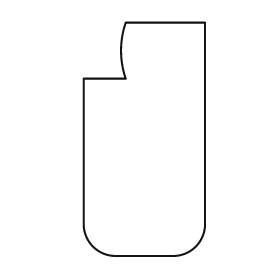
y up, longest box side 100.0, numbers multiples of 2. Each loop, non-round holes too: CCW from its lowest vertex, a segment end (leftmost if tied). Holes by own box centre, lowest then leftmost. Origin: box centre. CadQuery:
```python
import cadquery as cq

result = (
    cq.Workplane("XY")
    .moveTo(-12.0, -50.0)
    .lineTo(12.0, -50.0)
    .threePointArc((22.0, -46.0), (26.0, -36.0))
    .lineTo(26.0, 50.0)
    .lineTo(-8.0, 50.0)
    .threePointArc((-10.0, 38.0), (-8.0, 26.0))
    .lineTo(-26.0, 26.0)
    .lineTo(-26.0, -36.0)
    .threePointArc((-22.0, -46.0), (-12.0, -50.0))
    .close()
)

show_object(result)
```